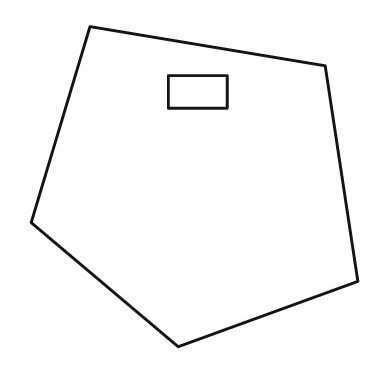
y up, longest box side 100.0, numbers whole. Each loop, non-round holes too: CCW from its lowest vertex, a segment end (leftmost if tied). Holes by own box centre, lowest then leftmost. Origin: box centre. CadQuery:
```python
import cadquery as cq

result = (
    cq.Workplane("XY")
    .moveTo(-5.0, -49.0)
    .lineTo(50.0, -29.0)
    .lineTo(40.0, 37.0)
    .lineTo(-32.0, 49.0)
    .lineTo(-50.0, -11.0)
    .close()
    .moveTo(-8.0, 24.0)
    .lineTo(10.0, 24.0)
    .lineTo(10.0, 34.0)
    .lineTo(-8.0, 34.0)
    .close()
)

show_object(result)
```